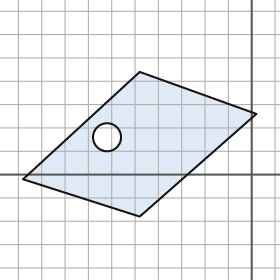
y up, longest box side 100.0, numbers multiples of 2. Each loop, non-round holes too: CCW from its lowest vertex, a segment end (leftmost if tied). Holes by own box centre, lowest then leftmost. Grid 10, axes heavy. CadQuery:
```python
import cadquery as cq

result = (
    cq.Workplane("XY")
    .moveTo(-48.0, -18.0)
    .lineTo(2.0, 26.0)
    .lineTo(-48.0, 44.0)
    .lineTo(-98.0, -2.0)
    .close()
    .moveTo(-62.0, 16.0)
    .circle(6.0)
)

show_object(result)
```